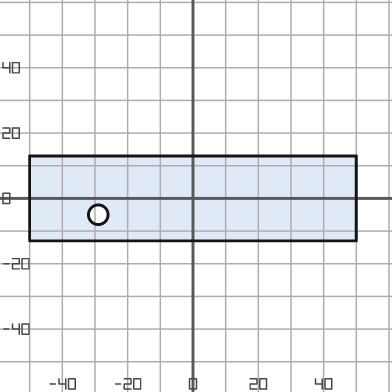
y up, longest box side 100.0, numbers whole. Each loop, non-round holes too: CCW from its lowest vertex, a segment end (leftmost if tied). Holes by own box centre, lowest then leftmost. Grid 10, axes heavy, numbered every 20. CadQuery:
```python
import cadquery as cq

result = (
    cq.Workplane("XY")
    .moveTo(-50.0, -13.0)
    .lineTo(50.0, -13.0)
    .lineTo(50.0, 13.0)
    .lineTo(-50.0, 13.0)
    .close()
    .moveTo(-29.0, -5.0)
    .circle(3.0)
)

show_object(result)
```